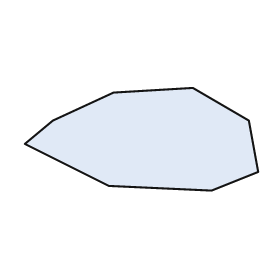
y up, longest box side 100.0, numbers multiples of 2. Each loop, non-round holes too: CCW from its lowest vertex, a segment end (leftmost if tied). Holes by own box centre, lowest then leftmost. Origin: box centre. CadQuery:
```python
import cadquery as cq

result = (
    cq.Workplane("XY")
    .moveTo(30.0, -22.0)
    .lineTo(50.0, -14.0)
    .lineTo(46.0, 8.0)
    .lineTo(22.0, 22.0)
    .lineTo(-12.0, 20.0)
    .lineTo(-38.0, 8.0)
    .lineTo(-50.0, -2.0)
    .lineTo(-14.0, -20.0)
    .close()
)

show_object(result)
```